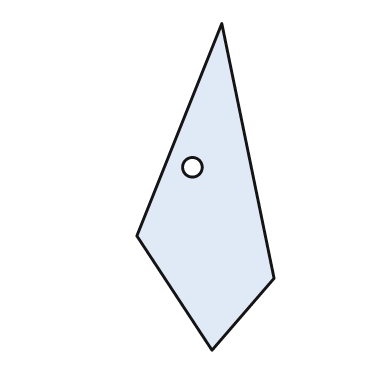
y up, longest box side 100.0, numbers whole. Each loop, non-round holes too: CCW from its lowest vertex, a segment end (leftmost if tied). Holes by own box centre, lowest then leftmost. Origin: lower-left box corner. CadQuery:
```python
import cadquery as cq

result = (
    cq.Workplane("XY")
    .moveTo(23.0, 0.0)
    .lineTo(42.0, 22.0)
    .lineTo(26.0, 100.0)
    .lineTo(0.0, 35.0)
    .close()
    .moveTo(17.0, 56.0)
    .circle(3.0)
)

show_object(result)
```